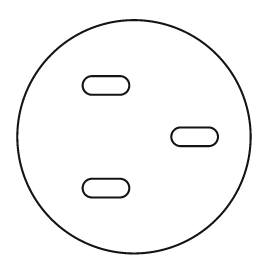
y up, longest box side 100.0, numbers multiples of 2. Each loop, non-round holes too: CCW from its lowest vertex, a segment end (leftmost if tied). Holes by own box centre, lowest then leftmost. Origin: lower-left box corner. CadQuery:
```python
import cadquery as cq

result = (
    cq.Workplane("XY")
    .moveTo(50.0, 50.0)
    .circle(50.0)
    .moveTo(32.0, 24.0)
    .lineTo(44.0, 24.0)
    .threePointArc((48.0, 28.0), (44.0, 32.0))
    .lineTo(32.0, 32.0)
    .threePointArc((28.0, 28.0), (32.0, 24.0))
    .close()
    .moveTo(70.0, 46.0)
    .lineTo(82.0, 46.0)
    .threePointArc((86.0, 50.0), (82.0, 54.0))
    .lineTo(70.0, 54.0)
    .threePointArc((66.0, 50.0), (70.0, 46.0))
    .close()
    .moveTo(32.0, 68.0)
    .lineTo(44.0, 68.0)
    .threePointArc((48.0, 72.0), (44.0, 76.0))
    .lineTo(32.0, 76.0)
    .threePointArc((28.0, 72.0), (32.0, 68.0))
    .close()
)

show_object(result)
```